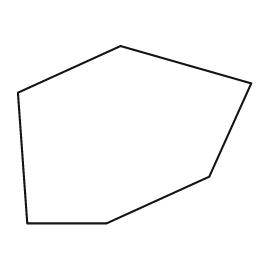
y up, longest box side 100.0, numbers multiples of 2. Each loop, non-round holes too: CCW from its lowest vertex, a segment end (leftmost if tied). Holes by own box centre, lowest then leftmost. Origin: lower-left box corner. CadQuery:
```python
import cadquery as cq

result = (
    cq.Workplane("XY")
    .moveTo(4.0, 0.0)
    .lineTo(38.0, 0.0)
    .lineTo(82.0, 20.0)
    .lineTo(100.0, 60.0)
    .lineTo(44.0, 76.0)
    .lineTo(0.0, 56.0)
    .close()
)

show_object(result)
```